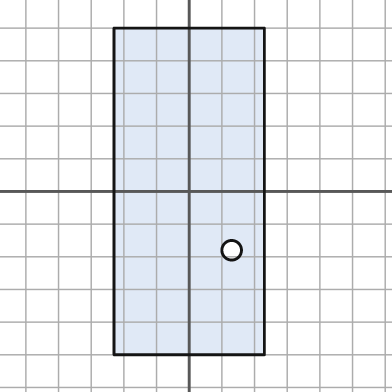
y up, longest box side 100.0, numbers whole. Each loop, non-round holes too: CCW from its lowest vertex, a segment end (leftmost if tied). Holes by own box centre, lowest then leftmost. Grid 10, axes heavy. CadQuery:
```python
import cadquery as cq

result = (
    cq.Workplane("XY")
    .moveTo(-23.0, -50.0)
    .lineTo(23.0, -50.0)
    .lineTo(23.0, 50.0)
    .lineTo(-23.0, 50.0)
    .close()
    .moveTo(13.0, -18.0)
    .circle(3.0)
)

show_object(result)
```